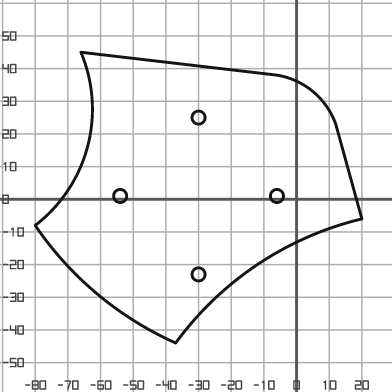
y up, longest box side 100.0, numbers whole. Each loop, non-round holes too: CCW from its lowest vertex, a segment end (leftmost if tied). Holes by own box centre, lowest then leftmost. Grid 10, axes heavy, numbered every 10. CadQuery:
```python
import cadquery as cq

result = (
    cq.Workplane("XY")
    .moveTo(-37.0, -44.0)
    .threePointArc((-12.0, -20.0), (20.0, -6.0))
    .lineTo(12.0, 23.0)
    .threePointArc((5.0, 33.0), (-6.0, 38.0))
    .lineTo(-66.0, 45.0)
    .threePointArc((-64.0, 16.0), (-80.0, -8.0))
    .threePointArc((-61.0, -29.0), (-37.0, -44.0))
    .close()
    .moveTo(-30.0, -23.0)
    .circle(2.0)
    .moveTo(-54.0, 1.0)
    .circle(2.0)
    .moveTo(-6.0, 1.0)
    .circle(2.0)
    .moveTo(-30.0, 25.0)
    .circle(2.0)
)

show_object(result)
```